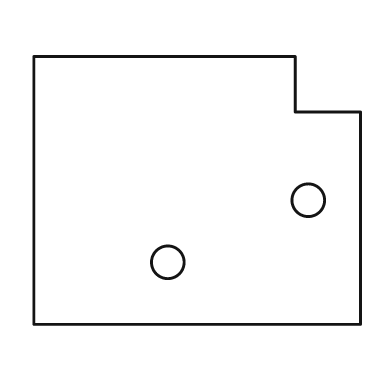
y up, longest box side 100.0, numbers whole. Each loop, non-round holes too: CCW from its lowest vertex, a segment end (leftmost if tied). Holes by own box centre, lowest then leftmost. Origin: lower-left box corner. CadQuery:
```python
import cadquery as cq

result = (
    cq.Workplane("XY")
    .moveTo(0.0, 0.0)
    .lineTo(100.0, 0.0)
    .lineTo(100.0, 65.0)
    .lineTo(80.0, 65.0)
    .lineTo(80.0, 82.0)
    .lineTo(0.0, 82.0)
    .close()
    .moveTo(41.0, 19.0)
    .circle(5.0)
    .moveTo(84.0, 38.0)
    .circle(5.0)
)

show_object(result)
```